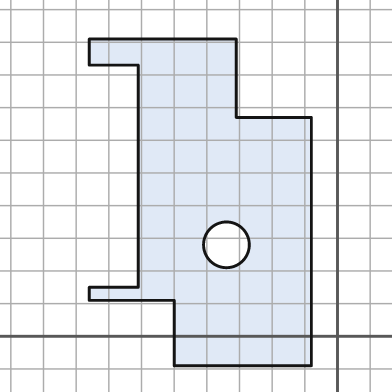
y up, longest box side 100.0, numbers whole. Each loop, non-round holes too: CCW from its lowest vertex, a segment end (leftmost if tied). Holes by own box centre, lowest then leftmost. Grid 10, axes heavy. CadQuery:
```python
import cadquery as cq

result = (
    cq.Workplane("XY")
    .moveTo(-50.0, -9.0)
    .lineTo(-8.0, -9.0)
    .lineTo(-8.0, 67.0)
    .lineTo(-31.0, 67.0)
    .lineTo(-31.0, 91.0)
    .lineTo(-76.0, 91.0)
    .lineTo(-76.0, 83.0)
    .lineTo(-61.0, 83.0)
    .lineTo(-61.0, 15.0)
    .lineTo(-76.0, 15.0)
    .lineTo(-76.0, 11.0)
    .lineTo(-50.0, 11.0)
    .close()
    .moveTo(-34.0, 28.0)
    .circle(7.0)
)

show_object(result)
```